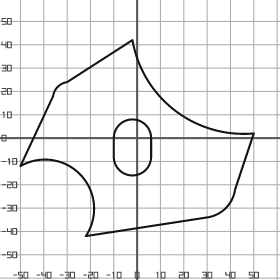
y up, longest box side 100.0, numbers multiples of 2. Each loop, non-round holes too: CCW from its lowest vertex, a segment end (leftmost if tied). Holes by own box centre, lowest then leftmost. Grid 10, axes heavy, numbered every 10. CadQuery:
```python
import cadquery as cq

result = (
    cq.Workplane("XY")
    .moveTo(-22.0, -42.0)
    .lineTo(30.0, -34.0)
    .threePointArc((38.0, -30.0), (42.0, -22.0))
    .lineTo(50.0, 2.0)
    .threePointArc((16.0, 12.0), (-2.0, 42.0))
    .lineTo(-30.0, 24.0)
    .threePointArc((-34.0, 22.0), (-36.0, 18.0))
    .lineTo(-50.0, -12.0)
    .threePointArc((-24.0, -16.0), (-22.0, -42.0))
    .close()
    .moveTo(-10.0, -8.0)
    .threePointArc((-2.0, -16.0), (6.0, -8.0))
    .lineTo(6.0, 0.0)
    .threePointArc((-2.0, 8.0), (-10.0, 0.0))
    .close()
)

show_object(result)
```